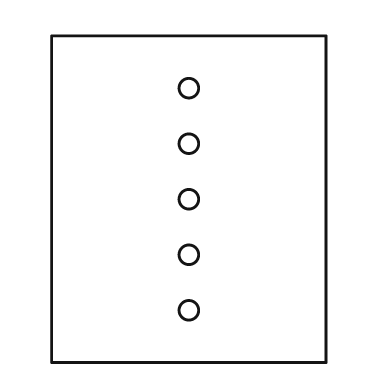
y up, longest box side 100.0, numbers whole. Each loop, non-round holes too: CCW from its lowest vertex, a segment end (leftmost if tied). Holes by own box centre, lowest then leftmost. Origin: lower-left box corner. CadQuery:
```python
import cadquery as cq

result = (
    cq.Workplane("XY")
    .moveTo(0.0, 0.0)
    .lineTo(84.0, 0.0)
    .lineTo(84.0, 100.0)
    .lineTo(0.0, 100.0)
    .close()
    .moveTo(42.0, 16.0)
    .circle(3.0)
    .moveTo(42.0, 33.0)
    .circle(3.0)
    .moveTo(42.0, 50.0)
    .circle(3.0)
    .moveTo(42.0, 67.0)
    .circle(3.0)
    .moveTo(42.0, 84.0)
    .circle(3.0)
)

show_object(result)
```